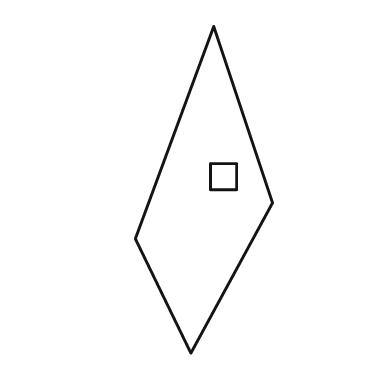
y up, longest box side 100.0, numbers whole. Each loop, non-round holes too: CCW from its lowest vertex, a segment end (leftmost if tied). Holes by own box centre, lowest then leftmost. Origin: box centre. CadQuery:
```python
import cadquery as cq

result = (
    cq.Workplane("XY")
    .moveTo(-4.0, -50.0)
    .lineTo(21.0, -4.0)
    .lineTo(3.0, 50.0)
    .lineTo(-21.0, -15.0)
    .close()
    .moveTo(2.0, 0.0)
    .lineTo(10.0, 0.0)
    .lineTo(10.0, 8.0)
    .lineTo(2.0, 8.0)
    .close()
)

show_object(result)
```